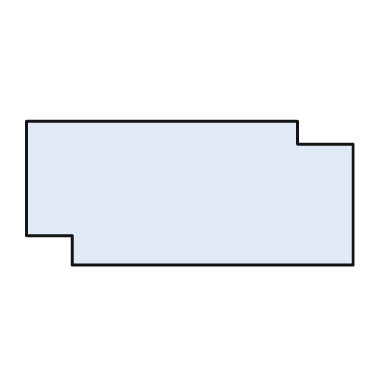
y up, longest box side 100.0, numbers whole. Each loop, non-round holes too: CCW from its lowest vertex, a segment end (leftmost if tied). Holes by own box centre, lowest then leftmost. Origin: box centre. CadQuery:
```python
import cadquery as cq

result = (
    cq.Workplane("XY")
    .moveTo(-36.0, -22.0)
    .lineTo(50.0, -22.0)
    .lineTo(50.0, 15.0)
    .lineTo(33.0, 15.0)
    .lineTo(33.0, 22.0)
    .lineTo(-50.0, 22.0)
    .lineTo(-50.0, -13.0)
    .lineTo(-36.0, -13.0)
    .close()
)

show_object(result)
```